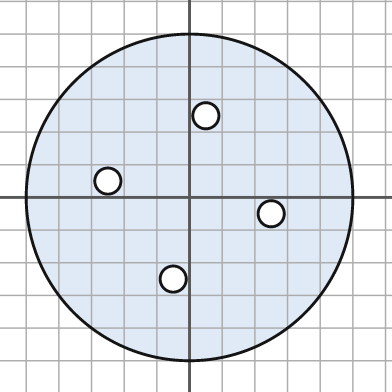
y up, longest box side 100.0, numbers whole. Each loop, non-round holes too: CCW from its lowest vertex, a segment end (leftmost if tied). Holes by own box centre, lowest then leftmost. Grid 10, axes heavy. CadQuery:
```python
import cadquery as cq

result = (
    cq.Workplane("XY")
    .moveTo(0.0, 0.0)
    .circle(50.0)
    .moveTo(-5.0, -25.0)
    .circle(4.0)
    .moveTo(25.0, -5.0)
    .circle(4.0)
    .moveTo(-25.0, 5.0)
    .circle(4.0)
    .moveTo(5.0, 25.0)
    .circle(4.0)
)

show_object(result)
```